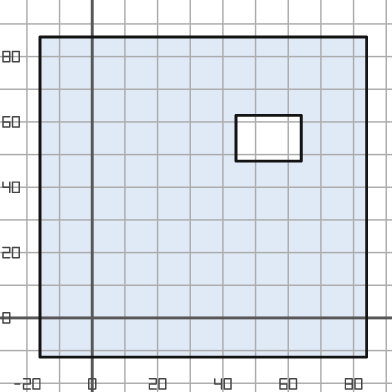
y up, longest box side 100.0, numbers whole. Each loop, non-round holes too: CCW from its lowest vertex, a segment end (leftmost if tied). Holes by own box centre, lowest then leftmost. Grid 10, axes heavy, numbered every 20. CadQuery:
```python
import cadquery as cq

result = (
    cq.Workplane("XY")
    .moveTo(-16.0, -12.0)
    .lineTo(84.0, -12.0)
    .lineTo(84.0, 86.0)
    .lineTo(-16.0, 86.0)
    .close()
    .moveTo(44.0, 48.0)
    .lineTo(64.0, 48.0)
    .lineTo(64.0, 62.0)
    .lineTo(44.0, 62.0)
    .close()
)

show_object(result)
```